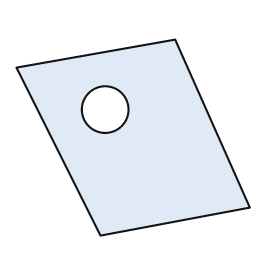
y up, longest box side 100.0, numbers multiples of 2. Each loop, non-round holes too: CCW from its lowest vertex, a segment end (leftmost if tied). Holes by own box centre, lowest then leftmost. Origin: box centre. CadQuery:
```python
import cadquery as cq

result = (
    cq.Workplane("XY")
    .moveTo(-14.0, -42.0)
    .lineTo(50.0, -30.0)
    .lineTo(18.0, 42.0)
    .lineTo(-50.0, 30.0)
    .close()
    .moveTo(-12.0, 12.0)
    .circle(10.0)
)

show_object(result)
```